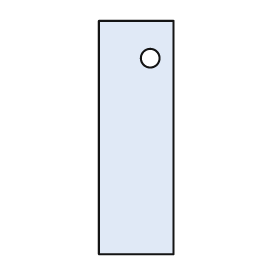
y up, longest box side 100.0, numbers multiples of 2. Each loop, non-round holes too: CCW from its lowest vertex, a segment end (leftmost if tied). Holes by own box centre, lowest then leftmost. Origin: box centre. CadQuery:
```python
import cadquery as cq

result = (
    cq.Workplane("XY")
    .moveTo(-16.0, -50.0)
    .lineTo(16.0, -50.0)
    .lineTo(16.0, 50.0)
    .lineTo(-16.0, 50.0)
    .close()
    .moveTo(6.0, 34.0)
    .circle(4.0)
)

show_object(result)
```